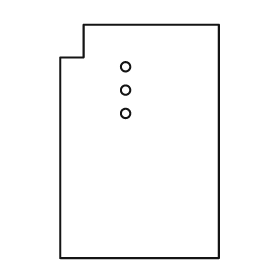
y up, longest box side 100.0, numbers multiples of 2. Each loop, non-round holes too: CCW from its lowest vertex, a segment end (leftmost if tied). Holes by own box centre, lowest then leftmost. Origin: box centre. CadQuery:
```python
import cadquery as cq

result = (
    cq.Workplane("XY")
    .moveTo(-34.0, -50.0)
    .lineTo(34.0, -50.0)
    .lineTo(34.0, 50.0)
    .lineTo(-24.0, 50.0)
    .lineTo(-24.0, 36.0)
    .lineTo(-34.0, 36.0)
    .close()
    .moveTo(-6.0, 12.0)
    .circle(2.0)
    .moveTo(-6.0, 22.0)
    .circle(2.0)
    .moveTo(-6.0, 32.0)
    .circle(2.0)
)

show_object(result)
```